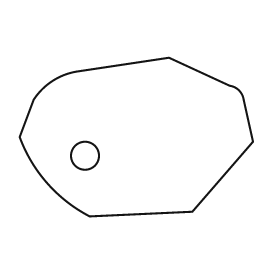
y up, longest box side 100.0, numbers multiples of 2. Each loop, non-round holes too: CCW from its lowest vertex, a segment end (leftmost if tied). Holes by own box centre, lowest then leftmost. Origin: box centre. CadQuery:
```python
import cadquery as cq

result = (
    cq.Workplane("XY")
    .moveTo(-20.0, -34.0)
    .lineTo(24.0, -32.0)
    .lineTo(50.0, -2.0)
    .lineTo(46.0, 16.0)
    .threePointArc((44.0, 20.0), (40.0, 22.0))
    .lineTo(14.0, 34.0)
    .lineTo(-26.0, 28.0)
    .threePointArc((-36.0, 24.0), (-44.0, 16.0))
    .lineTo(-50.0, 0.0)
    .threePointArc((-38.0, -20.0), (-20.0, -34.0))
    .close()
    .moveTo(-22.0, -8.0)
    .circle(6.0)
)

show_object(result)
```